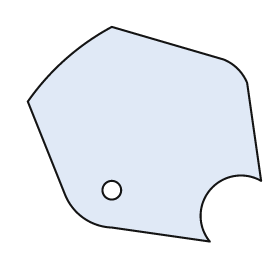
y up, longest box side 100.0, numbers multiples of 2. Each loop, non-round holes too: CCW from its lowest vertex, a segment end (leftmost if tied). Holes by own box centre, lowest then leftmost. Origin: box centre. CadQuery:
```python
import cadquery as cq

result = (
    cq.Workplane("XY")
    .moveTo(28.0, -46.0)
    .threePointArc((28.0, -24.0), (50.0, -20.0))
    .lineTo(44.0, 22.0)
    .threePointArc((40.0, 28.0), (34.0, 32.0))
    .lineTo(-14.0, 46.0)
    .threePointArc((-34.0, 32.0), (-50.0, 14.0))
    .lineTo(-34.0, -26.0)
    .threePointArc((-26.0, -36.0), (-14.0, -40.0))
    .close()
    .moveTo(-14.0, -24.0)
    .circle(4.0)
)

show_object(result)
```